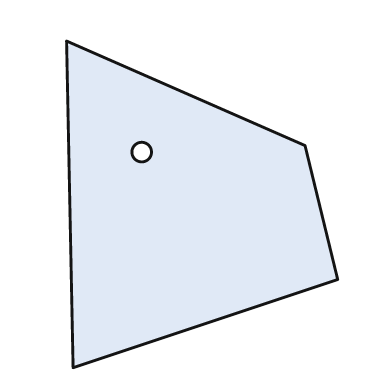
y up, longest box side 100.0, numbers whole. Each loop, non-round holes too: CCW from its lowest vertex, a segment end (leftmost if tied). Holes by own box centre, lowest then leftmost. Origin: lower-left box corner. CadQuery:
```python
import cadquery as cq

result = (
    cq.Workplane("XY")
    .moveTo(2.0, 0.0)
    .lineTo(83.0, 27.0)
    .lineTo(73.0, 68.0)
    .lineTo(0.0, 100.0)
    .close()
    .moveTo(23.0, 66.0)
    .circle(3.0)
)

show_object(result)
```